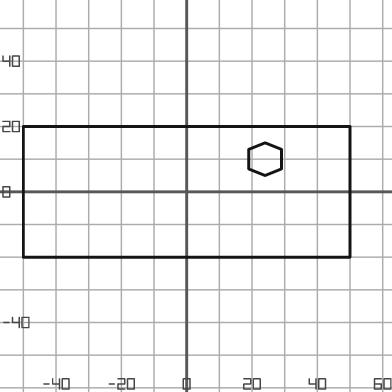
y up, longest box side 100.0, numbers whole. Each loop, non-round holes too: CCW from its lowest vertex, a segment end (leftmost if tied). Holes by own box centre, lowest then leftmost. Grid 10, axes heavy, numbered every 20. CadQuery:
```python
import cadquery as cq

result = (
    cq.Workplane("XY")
    .moveTo(-50.0, -20.0)
    .lineTo(50.0, -20.0)
    .lineTo(50.0, 20.0)
    .lineTo(-50.0, 20.0)
    .close()
    .moveTo(24.0, 5.0)
    .lineTo(29.0, 7.0)
    .lineTo(29.0, 13.0)
    .lineTo(24.0, 15.0)
    .lineTo(19.0, 13.0)
    .lineTo(19.0, 7.0)
    .close()
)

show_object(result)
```